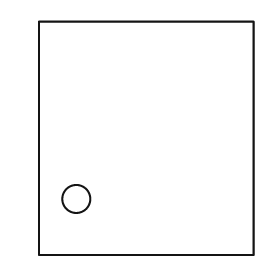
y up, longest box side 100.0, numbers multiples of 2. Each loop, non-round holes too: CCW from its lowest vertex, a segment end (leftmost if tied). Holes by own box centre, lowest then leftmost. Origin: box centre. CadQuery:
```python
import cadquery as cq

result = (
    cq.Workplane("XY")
    .moveTo(-46.0, -50.0)
    .lineTo(46.0, -50.0)
    .lineTo(46.0, 50.0)
    .lineTo(-46.0, 50.0)
    .close()
    .moveTo(-30.0, -26.0)
    .circle(6.0)
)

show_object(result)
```